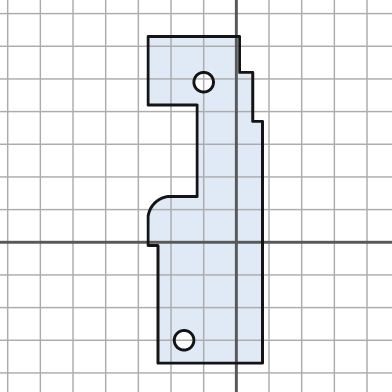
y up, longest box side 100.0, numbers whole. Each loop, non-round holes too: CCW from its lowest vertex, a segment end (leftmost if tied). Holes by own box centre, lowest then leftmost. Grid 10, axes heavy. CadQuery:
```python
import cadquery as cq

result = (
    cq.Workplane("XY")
    .moveTo(-24.0, -37.0)
    .lineTo(8.0, -37.0)
    .lineTo(8.0, 37.0)
    .lineTo(5.0, 37.0)
    .lineTo(5.0, 52.0)
    .lineTo(1.0, 52.0)
    .lineTo(1.0, 63.0)
    .lineTo(-27.0, 63.0)
    .lineTo(-27.0, 42.0)
    .lineTo(-12.0, 42.0)
    .lineTo(-12.0, 14.0)
    .lineTo(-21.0, 14.0)
    .threePointArc((-25.0, 12.0), (-27.0, 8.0))
    .lineTo(-27.0, -1.0)
    .lineTo(-24.0, -1.0)
    .close()
    .moveTo(-16.0, -30.0)
    .circle(3.0)
    .moveTo(-10.0, 49.0)
    .circle(3.0)
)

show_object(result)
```